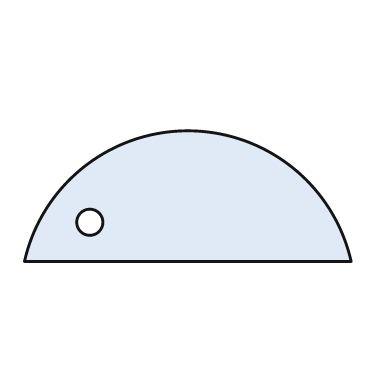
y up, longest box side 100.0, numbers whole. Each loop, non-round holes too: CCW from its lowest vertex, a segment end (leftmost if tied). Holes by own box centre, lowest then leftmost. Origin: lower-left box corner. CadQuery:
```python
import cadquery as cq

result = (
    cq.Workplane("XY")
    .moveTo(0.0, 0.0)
    .lineTo(100.0, 0.0)
    .threePointArc((50.0, 40.0), (0.0, 0.0))
    .close()
    .moveTo(20.0, 12.0)
    .circle(4.0)
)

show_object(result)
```